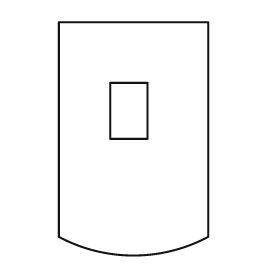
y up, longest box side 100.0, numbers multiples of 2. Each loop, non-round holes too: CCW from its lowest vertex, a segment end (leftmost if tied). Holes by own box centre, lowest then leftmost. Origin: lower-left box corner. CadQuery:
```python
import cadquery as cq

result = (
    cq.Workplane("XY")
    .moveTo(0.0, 8.0)
    .threePointArc((32.0, 0.0), (64.0, 8.0))
    .lineTo(64.0, 100.0)
    .lineTo(0.0, 100.0)
    .close()
    .moveTo(22.0, 50.0)
    .lineTo(38.0, 50.0)
    .lineTo(38.0, 74.0)
    .lineTo(22.0, 74.0)
    .close()
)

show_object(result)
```